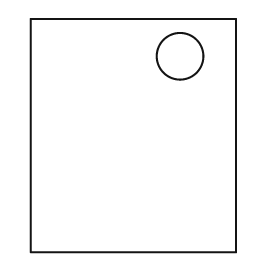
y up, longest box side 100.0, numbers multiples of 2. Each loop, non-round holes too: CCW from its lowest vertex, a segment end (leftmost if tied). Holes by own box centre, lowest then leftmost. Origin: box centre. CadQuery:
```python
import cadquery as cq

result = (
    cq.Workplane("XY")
    .moveTo(-44.0, -50.0)
    .lineTo(44.0, -50.0)
    .lineTo(44.0, 50.0)
    .lineTo(-44.0, 50.0)
    .close()
    .moveTo(20.0, 34.0)
    .circle(10.0)
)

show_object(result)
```